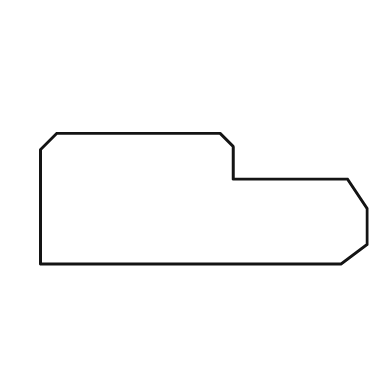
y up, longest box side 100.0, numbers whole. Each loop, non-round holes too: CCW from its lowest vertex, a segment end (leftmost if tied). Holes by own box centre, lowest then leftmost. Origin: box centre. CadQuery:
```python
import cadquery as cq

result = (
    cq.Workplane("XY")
    .moveTo(-50.0, -20.0)
    .lineTo(42.0, -20.0)
    .lineTo(50.0, -14.0)
    .lineTo(50.0, -3.0)
    .lineTo(44.0, 6.0)
    .lineTo(9.0, 6.0)
    .lineTo(9.0, 16.0)
    .lineTo(5.0, 20.0)
    .lineTo(-45.0, 20.0)
    .lineTo(-50.0, 15.0)
    .close()
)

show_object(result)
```